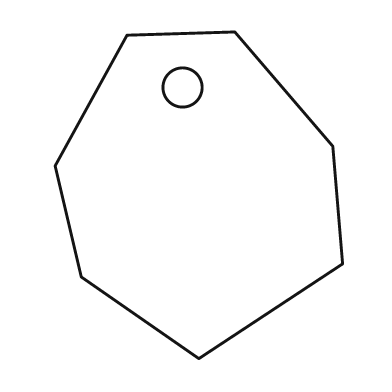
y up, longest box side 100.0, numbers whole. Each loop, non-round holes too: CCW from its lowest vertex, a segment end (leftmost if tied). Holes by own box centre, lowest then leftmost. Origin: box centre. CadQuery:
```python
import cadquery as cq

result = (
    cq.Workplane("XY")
    .moveTo(0.0, -50.0)
    .lineTo(44.0, -21.0)
    .lineTo(41.0, 15.0)
    .lineTo(11.0, 50.0)
    .lineTo(-22.0, 49.0)
    .lineTo(-44.0, 9.0)
    .lineTo(-36.0, -25.0)
    .close()
    .moveTo(-5.0, 33.0)
    .circle(6.0)
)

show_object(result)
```